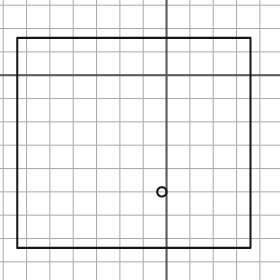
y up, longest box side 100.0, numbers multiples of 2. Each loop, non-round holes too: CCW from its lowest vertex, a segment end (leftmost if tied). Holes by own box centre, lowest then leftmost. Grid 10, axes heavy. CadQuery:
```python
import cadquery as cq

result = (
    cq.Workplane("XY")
    .moveTo(-64.0, -74.0)
    .lineTo(36.0, -74.0)
    .lineTo(36.0, 16.0)
    .lineTo(-64.0, 16.0)
    .close()
    .moveTo(-2.0, -50.0)
    .circle(2.0)
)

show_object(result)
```